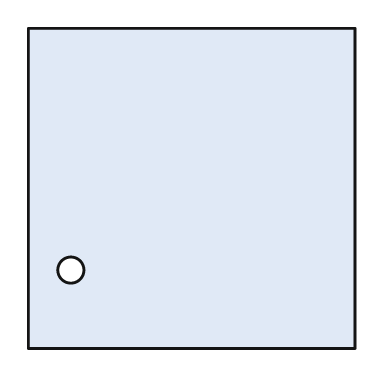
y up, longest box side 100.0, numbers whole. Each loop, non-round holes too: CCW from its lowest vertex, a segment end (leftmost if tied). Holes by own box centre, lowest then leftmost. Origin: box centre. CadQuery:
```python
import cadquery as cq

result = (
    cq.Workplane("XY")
    .moveTo(-50.0, -49.0)
    .lineTo(50.0, -49.0)
    .lineTo(50.0, 49.0)
    .lineTo(-50.0, 49.0)
    .close()
    .moveTo(-37.0, -25.0)
    .circle(4.0)
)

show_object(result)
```